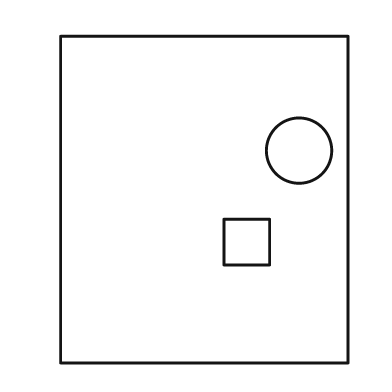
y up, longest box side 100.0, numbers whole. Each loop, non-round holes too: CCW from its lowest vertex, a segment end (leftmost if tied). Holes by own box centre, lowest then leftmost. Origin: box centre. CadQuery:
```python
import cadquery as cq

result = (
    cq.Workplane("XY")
    .moveTo(-44.0, -50.0)
    .lineTo(44.0, -50.0)
    .lineTo(44.0, 50.0)
    .lineTo(-44.0, 50.0)
    .close()
    .moveTo(6.0, -20.0)
    .lineTo(20.0, -20.0)
    .lineTo(20.0, -6.0)
    .lineTo(6.0, -6.0)
    .close()
    .moveTo(29.0, 15.0)
    .circle(10.0)
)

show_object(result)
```